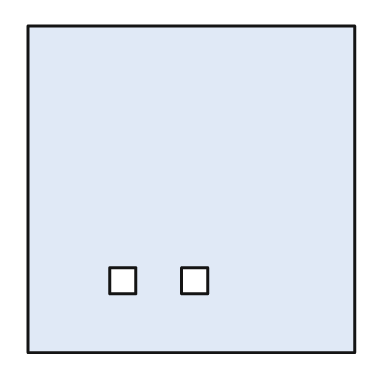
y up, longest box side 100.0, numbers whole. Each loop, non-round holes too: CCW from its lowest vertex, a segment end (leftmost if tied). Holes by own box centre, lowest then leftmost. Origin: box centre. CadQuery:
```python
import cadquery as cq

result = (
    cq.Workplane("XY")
    .moveTo(-50.0, -50.0)
    .lineTo(50.0, -50.0)
    .lineTo(50.0, 50.0)
    .lineTo(-50.0, 50.0)
    .close()
    .moveTo(-25.0, -32.0)
    .lineTo(-17.0, -32.0)
    .lineTo(-17.0, -24.0)
    .lineTo(-25.0, -24.0)
    .close()
    .moveTo(-3.0, -32.0)
    .lineTo(5.0, -32.0)
    .lineTo(5.0, -24.0)
    .lineTo(-3.0, -24.0)
    .close()
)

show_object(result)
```